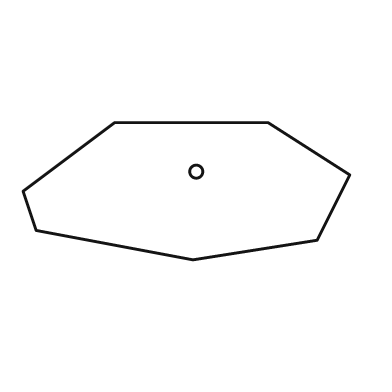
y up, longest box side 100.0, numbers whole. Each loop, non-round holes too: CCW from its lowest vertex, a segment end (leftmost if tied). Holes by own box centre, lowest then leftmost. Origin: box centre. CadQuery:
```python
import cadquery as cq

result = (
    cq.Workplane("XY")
    .moveTo(2.0, -21.0)
    .lineTo(40.0, -15.0)
    .lineTo(50.0, 5.0)
    .lineTo(25.0, 21.0)
    .lineTo(-22.0, 21.0)
    .lineTo(-50.0, 0.0)
    .lineTo(-46.0, -12.0)
    .close()
    .moveTo(3.0, 6.0)
    .circle(2.0)
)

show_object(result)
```